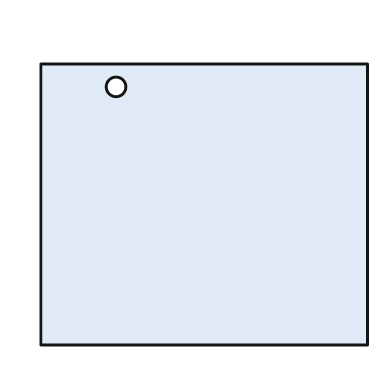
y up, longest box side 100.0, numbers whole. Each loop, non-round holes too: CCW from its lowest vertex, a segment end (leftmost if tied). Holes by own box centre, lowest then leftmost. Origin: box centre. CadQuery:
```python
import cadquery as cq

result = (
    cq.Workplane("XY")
    .moveTo(-50.0, -43.0)
    .lineTo(50.0, -43.0)
    .lineTo(50.0, 43.0)
    .lineTo(-50.0, 43.0)
    .close()
    .moveTo(-27.0, 36.0)
    .circle(3.0)
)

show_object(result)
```